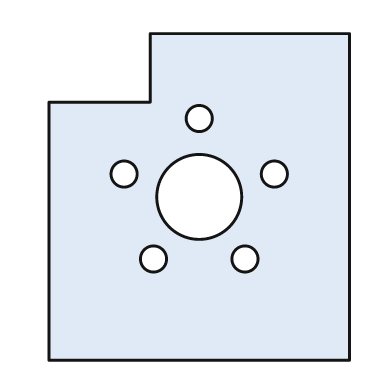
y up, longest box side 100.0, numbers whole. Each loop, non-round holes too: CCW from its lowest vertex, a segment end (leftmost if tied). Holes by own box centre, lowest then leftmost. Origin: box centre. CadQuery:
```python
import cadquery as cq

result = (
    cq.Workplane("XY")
    .moveTo(-46.0, -50.0)
    .lineTo(46.0, -50.0)
    .lineTo(46.0, 50.0)
    .lineTo(-15.0, 50.0)
    .lineTo(-15.0, 29.0)
    .lineTo(-46.0, 29.0)
    .close()
    .moveTo(-14.0, -19.0)
    .circle(4.0)
    .moveTo(14.0, -19.0)
    .circle(4.0)
    .moveTo(0.0, 0.0)
    .circle(13.0)
    .moveTo(-23.0, 7.0)
    .circle(4.0)
    .moveTo(23.0, 7.0)
    .circle(4.0)
    .moveTo(0.0, 24.0)
    .circle(4.0)
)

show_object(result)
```